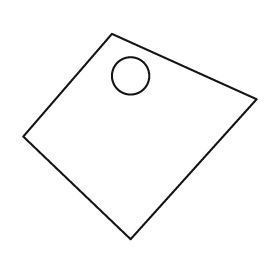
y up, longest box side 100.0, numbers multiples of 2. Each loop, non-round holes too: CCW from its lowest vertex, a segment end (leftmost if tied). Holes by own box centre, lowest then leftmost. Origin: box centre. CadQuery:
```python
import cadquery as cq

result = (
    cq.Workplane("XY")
    .moveTo(-4.0, -44.0)
    .lineTo(50.0, 16.0)
    .lineTo(-12.0, 44.0)
    .lineTo(-50.0, 0.0)
    .close()
    .moveTo(-4.0, 26.0)
    .circle(8.0)
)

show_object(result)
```